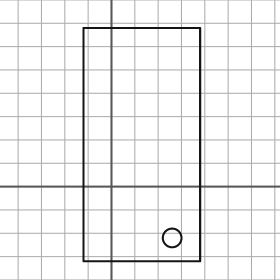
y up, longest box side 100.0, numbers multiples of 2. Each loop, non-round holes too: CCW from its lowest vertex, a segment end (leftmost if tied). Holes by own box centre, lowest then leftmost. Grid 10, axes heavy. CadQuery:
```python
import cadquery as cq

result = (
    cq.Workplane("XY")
    .moveTo(-12.0, -32.0)
    .lineTo(38.0, -32.0)
    .lineTo(38.0, 68.0)
    .lineTo(-12.0, 68.0)
    .close()
    .moveTo(26.0, -22.0)
    .circle(4.0)
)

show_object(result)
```